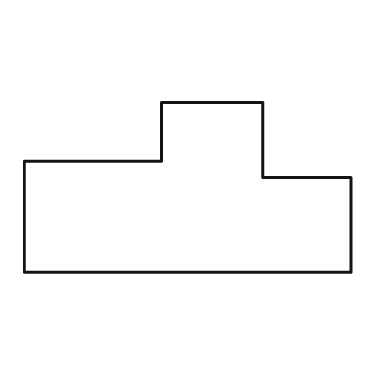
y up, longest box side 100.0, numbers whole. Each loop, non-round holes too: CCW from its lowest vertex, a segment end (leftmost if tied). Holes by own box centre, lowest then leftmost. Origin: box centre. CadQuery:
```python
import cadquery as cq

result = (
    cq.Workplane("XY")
    .moveTo(-50.0, -26.0)
    .lineTo(50.0, -26.0)
    .lineTo(50.0, 3.0)
    .lineTo(23.0, 3.0)
    .lineTo(23.0, 26.0)
    .lineTo(-8.0, 26.0)
    .lineTo(-8.0, 8.0)
    .lineTo(-50.0, 8.0)
    .close()
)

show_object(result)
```